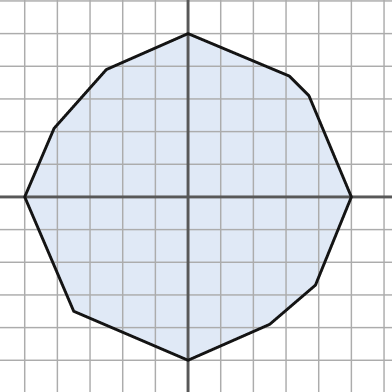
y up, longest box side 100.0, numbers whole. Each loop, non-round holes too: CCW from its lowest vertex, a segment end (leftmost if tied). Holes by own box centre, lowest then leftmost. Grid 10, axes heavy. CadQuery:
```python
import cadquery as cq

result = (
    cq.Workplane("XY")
    .moveTo(0.0, -50.0)
    .lineTo(25.0, -39.0)
    .lineTo(39.0, -27.0)
    .lineTo(50.0, 0.0)
    .lineTo(37.0, 31.0)
    .lineTo(31.0, 37.0)
    .lineTo(0.0, 50.0)
    .lineTo(-25.0, 39.0)
    .lineTo(-41.0, 21.0)
    .lineTo(-50.0, 0.0)
    .lineTo(-35.0, -35.0)
    .close()
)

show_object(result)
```